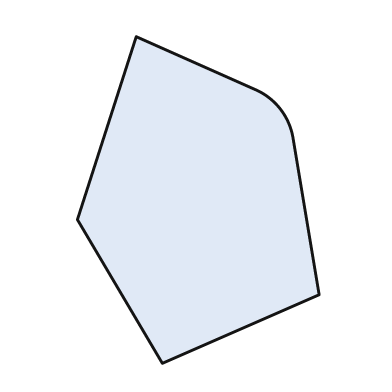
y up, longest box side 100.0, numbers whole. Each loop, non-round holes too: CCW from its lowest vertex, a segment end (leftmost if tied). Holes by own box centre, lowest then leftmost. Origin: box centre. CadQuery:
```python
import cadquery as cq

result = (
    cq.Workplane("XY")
    .moveTo(-11.0, -50.0)
    .lineTo(37.0, -29.0)
    .lineTo(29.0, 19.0)
    .threePointArc((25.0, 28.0), (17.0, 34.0))
    .lineTo(-19.0, 50.0)
    .lineTo(-37.0, -6.0)
    .close()
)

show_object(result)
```